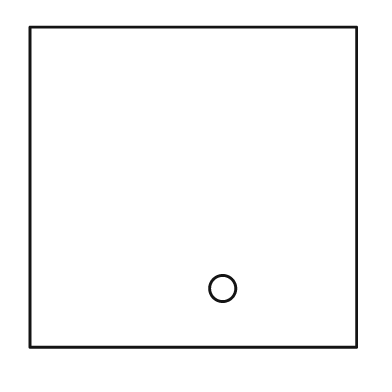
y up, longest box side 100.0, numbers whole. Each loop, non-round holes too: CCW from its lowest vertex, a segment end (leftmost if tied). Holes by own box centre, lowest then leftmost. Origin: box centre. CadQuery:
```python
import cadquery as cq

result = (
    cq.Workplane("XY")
    .moveTo(-50.0, -49.0)
    .lineTo(50.0, -49.0)
    .lineTo(50.0, 49.0)
    .lineTo(-50.0, 49.0)
    .close()
    .moveTo(9.0, -31.0)
    .circle(4.0)
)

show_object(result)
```